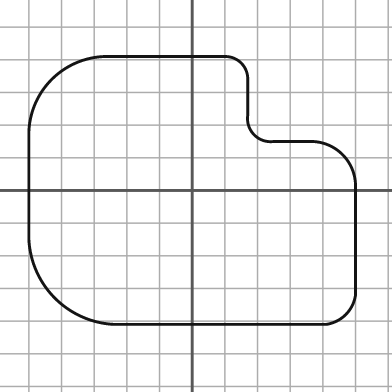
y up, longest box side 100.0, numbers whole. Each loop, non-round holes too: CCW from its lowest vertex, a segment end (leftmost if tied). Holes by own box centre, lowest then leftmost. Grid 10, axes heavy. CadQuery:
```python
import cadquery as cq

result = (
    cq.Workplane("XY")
    .moveTo(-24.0, -41.0)
    .lineTo(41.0, -41.0)
    .threePointArc((47.0, -38.0), (50.0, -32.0))
    .lineTo(50.0, 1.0)
    .threePointArc((46.0, 11.0), (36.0, 15.0))
    .lineTo(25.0, 15.0)
    .threePointArc((19.0, 17.0), (17.0, 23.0))
    .lineTo(17.0, 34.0)
    .threePointArc((15.0, 39.0), (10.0, 41.0))
    .lineTo(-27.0, 41.0)
    .threePointArc((-43.0, 34.0), (-50.0, 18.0))
    .lineTo(-50.0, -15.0)
    .threePointArc((-42.0, -33.0), (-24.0, -41.0))
    .close()
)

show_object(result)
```